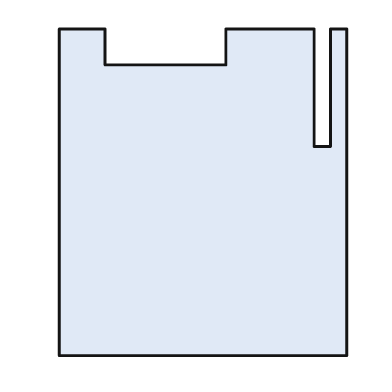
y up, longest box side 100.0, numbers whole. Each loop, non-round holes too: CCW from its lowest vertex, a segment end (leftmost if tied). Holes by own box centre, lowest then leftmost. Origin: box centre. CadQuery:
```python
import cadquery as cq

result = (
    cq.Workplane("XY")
    .moveTo(-44.0, -50.0)
    .lineTo(44.0, -50.0)
    .lineTo(44.0, 50.0)
    .lineTo(39.0, 50.0)
    .lineTo(39.0, 14.0)
    .lineTo(34.0, 14.0)
    .lineTo(34.0, 50.0)
    .lineTo(7.0, 50.0)
    .lineTo(7.0, 39.0)
    .lineTo(-30.0, 39.0)
    .lineTo(-30.0, 50.0)
    .lineTo(-44.0, 50.0)
    .close()
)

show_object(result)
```